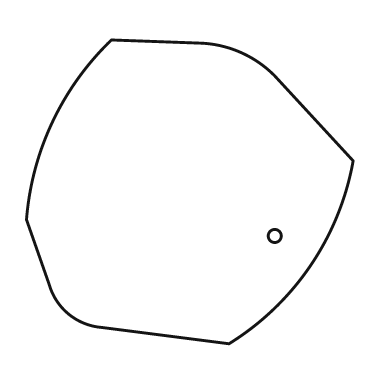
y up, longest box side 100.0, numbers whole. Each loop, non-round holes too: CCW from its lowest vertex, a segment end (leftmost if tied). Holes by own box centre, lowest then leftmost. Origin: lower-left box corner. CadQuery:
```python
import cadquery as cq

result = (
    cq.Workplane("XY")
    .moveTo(62.0, 0.0)
    .threePointArc((87.0, 24.0), (100.0, 56.0))
    .lineTo(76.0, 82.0)
    .threePointArc((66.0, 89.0), (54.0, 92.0))
    .lineTo(26.0, 93.0)
    .threePointArc((8.0, 68.0), (0.0, 38.0))
    .lineTo(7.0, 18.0)
    .threePointArc((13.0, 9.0), (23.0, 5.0))
    .close()
    .moveTo(76.0, 33.0)
    .circle(2.0)
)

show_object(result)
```